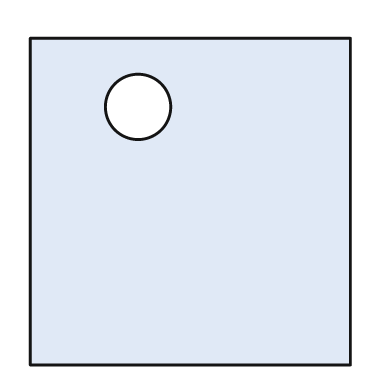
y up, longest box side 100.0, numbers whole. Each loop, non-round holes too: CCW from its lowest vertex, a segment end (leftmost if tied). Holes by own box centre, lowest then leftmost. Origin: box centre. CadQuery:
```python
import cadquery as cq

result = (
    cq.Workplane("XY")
    .moveTo(-49.0, -50.0)
    .lineTo(49.0, -50.0)
    .lineTo(49.0, 50.0)
    .lineTo(-49.0, 50.0)
    .close()
    .moveTo(-16.0, 29.0)
    .circle(10.0)
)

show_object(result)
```